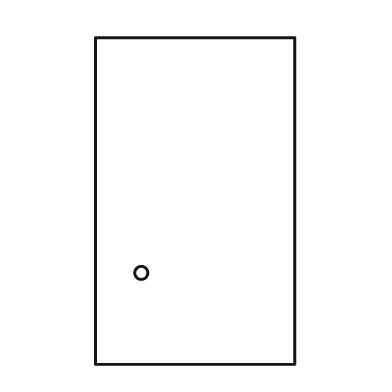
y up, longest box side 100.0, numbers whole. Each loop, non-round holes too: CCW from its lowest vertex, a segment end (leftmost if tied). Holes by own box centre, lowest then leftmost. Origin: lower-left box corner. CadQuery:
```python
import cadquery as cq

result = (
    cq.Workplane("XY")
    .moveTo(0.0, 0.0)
    .lineTo(61.0, 0.0)
    .lineTo(61.0, 100.0)
    .lineTo(0.0, 100.0)
    .close()
    .moveTo(14.0, 28.0)
    .circle(2.0)
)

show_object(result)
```